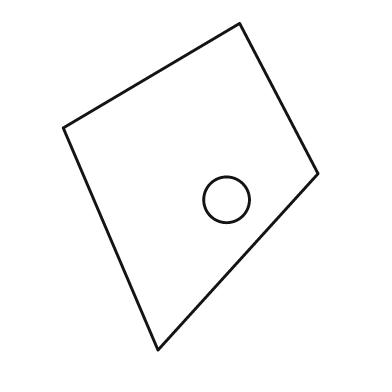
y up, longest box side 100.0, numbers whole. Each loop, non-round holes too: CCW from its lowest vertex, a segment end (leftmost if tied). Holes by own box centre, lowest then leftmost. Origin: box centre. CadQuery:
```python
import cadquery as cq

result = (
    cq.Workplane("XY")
    .moveTo(-10.0, -50.0)
    .lineTo(39.0, 4.0)
    .lineTo(15.0, 50.0)
    .lineTo(-39.0, 18.0)
    .close()
    .moveTo(11.0, -4.0)
    .circle(7.0)
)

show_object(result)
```